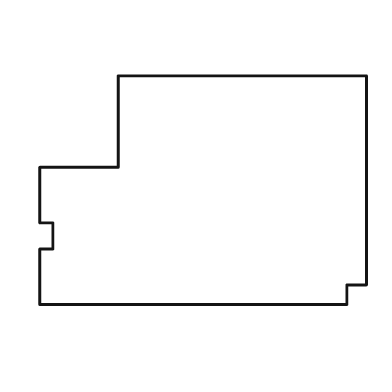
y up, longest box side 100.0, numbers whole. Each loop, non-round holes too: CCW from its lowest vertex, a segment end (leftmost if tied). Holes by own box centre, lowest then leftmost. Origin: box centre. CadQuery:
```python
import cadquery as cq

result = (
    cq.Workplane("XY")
    .moveTo(-50.0, -35.0)
    .lineTo(44.0, -35.0)
    .lineTo(44.0, -29.0)
    .lineTo(50.0, -29.0)
    .lineTo(50.0, 35.0)
    .lineTo(-26.0, 35.0)
    .lineTo(-26.0, 7.0)
    .lineTo(-50.0, 7.0)
    .lineTo(-50.0, -10.0)
    .lineTo(-46.0, -10.0)
    .lineTo(-46.0, -18.0)
    .lineTo(-50.0, -18.0)
    .close()
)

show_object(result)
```